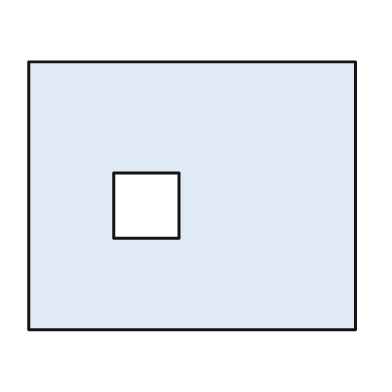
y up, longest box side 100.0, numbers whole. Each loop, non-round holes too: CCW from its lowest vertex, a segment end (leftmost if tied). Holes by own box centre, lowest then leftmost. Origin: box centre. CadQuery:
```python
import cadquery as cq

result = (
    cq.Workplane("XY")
    .moveTo(-50.0, -41.0)
    .lineTo(50.0, -41.0)
    .lineTo(50.0, 41.0)
    .lineTo(-50.0, 41.0)
    .close()
    .moveTo(-24.0, -13.0)
    .lineTo(-4.0, -13.0)
    .lineTo(-4.0, 7.0)
    .lineTo(-24.0, 7.0)
    .close()
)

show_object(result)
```